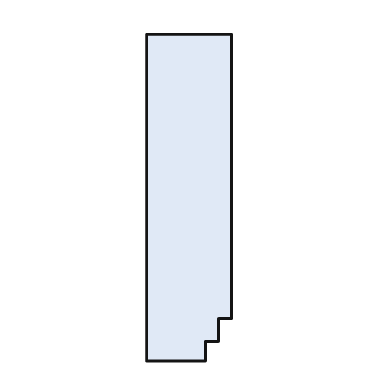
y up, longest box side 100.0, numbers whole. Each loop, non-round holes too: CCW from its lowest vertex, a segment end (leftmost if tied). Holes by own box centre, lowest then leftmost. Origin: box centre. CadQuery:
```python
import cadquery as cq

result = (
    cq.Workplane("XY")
    .moveTo(-13.0, -50.0)
    .lineTo(5.0, -50.0)
    .lineTo(5.0, -44.0)
    .lineTo(9.0, -44.0)
    .lineTo(9.0, -37.0)
    .lineTo(13.0, -37.0)
    .lineTo(13.0, 50.0)
    .lineTo(-13.0, 50.0)
    .close()
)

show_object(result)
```